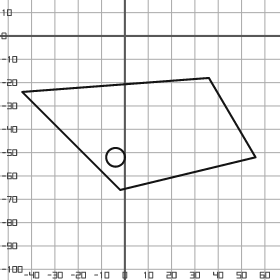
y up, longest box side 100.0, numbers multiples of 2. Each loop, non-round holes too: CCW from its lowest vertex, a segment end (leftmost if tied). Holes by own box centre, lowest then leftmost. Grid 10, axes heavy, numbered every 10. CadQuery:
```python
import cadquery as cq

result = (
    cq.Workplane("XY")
    .moveTo(-2.0, -66.0)
    .lineTo(56.0, -52.0)
    .lineTo(36.0, -18.0)
    .lineTo(-44.0, -24.0)
    .close()
    .moveTo(-4.0, -52.0)
    .circle(4.0)
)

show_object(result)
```